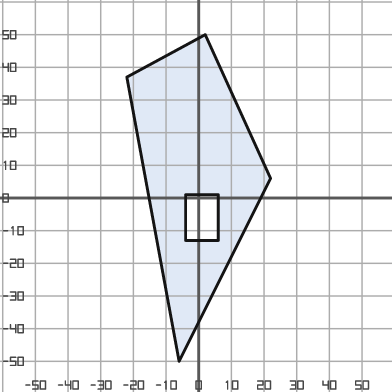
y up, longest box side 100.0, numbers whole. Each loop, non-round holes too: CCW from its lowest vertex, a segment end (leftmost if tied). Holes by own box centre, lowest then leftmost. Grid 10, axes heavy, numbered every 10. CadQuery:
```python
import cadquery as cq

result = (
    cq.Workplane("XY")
    .moveTo(-6.0, -50.0)
    .lineTo(22.0, 6.0)
    .lineTo(2.0, 50.0)
    .lineTo(-22.0, 37.0)
    .close()
    .moveTo(-4.0, -13.0)
    .lineTo(6.0, -13.0)
    .lineTo(6.0, 1.0)
    .lineTo(-4.0, 1.0)
    .close()
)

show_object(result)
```